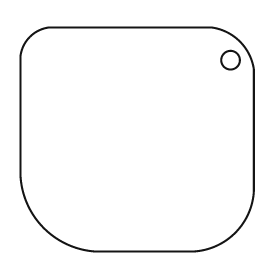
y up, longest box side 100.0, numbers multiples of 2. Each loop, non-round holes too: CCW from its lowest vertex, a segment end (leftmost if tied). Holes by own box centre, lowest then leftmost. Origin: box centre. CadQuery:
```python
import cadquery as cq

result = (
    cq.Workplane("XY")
    .moveTo(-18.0, -48.0)
    .lineTo(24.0, -48.0)
    .threePointArc((42.0, -40.0), (50.0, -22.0))
    .lineTo(50.0, 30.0)
    .threePointArc((44.0, 42.0), (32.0, 48.0))
    .lineTo(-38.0, 48.0)
    .threePointArc((-46.0, 44.0), (-50.0, 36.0))
    .lineTo(-50.0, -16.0)
    .threePointArc((-40.0, -38.0), (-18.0, -48.0))
    .close()
    .moveTo(40.0, 34.0)
    .circle(4.0)
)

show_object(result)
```